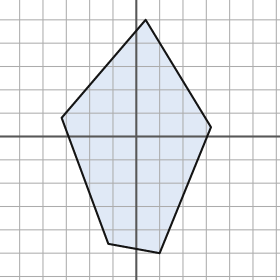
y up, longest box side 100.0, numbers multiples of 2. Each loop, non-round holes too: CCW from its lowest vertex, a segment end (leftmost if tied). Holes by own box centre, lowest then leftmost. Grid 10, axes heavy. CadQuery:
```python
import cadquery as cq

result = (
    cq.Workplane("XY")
    .moveTo(10.0, -50.0)
    .lineTo(32.0, 4.0)
    .lineTo(4.0, 50.0)
    .lineTo(-32.0, 8.0)
    .lineTo(-12.0, -46.0)
    .close()
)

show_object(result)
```